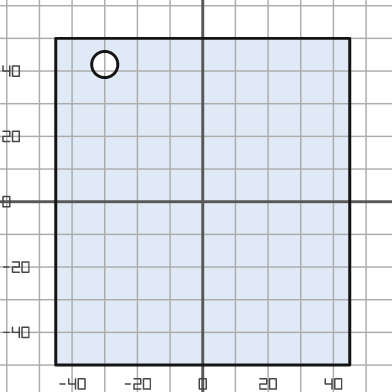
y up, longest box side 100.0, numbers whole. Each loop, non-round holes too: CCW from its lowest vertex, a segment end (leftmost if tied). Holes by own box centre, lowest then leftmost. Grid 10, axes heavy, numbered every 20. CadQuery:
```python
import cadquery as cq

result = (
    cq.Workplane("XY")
    .moveTo(-45.0, -50.0)
    .lineTo(45.0, -50.0)
    .lineTo(45.0, 50.0)
    .lineTo(-45.0, 50.0)
    .close()
    .moveTo(-30.0, 42.0)
    .circle(4.0)
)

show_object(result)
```